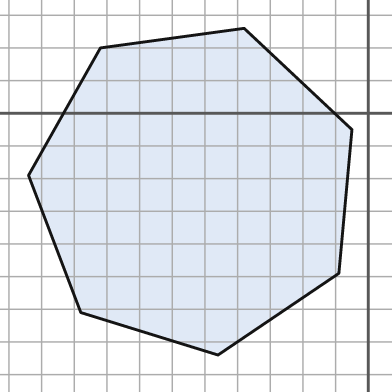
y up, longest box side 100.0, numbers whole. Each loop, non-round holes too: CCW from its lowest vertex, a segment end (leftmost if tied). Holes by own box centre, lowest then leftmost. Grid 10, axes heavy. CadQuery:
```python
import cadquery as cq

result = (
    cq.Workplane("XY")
    .moveTo(-46.0, -74.0)
    .lineTo(-9.0, -49.0)
    .lineTo(-5.0, -5.0)
    .lineTo(-38.0, 26.0)
    .lineTo(-82.0, 20.0)
    .lineTo(-104.0, -19.0)
    .lineTo(-88.0, -61.0)
    .close()
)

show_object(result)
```